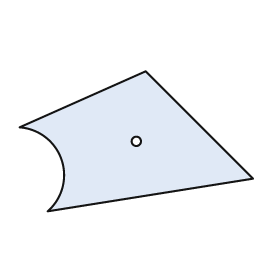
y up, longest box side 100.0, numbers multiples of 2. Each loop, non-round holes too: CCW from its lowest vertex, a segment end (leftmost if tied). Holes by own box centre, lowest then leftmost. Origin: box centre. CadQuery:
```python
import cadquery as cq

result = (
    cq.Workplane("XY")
    .moveTo(-38.0, -30.0)
    .lineTo(50.0, -16.0)
    .lineTo(4.0, 30.0)
    .lineTo(-50.0, 6.0)
    .threePointArc((-32.0, -8.0), (-38.0, -30.0))
    .close()
    .moveTo(0.0, 0.0)
    .circle(2.0)
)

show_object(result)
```